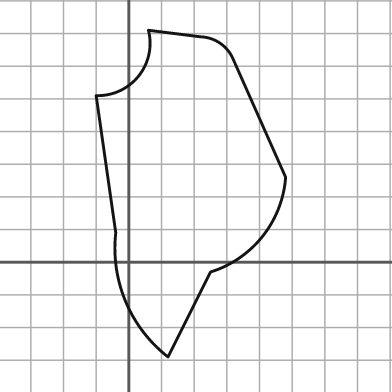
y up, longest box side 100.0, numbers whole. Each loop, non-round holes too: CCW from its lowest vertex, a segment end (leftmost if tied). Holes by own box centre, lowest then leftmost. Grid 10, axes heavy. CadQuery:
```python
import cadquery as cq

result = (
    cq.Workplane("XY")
    .moveTo(12.0, -29.0)
    .lineTo(25.0, -3.0)
    .threePointArc((41.0, 8.0), (48.0, 26.0))
    .lineTo(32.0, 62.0)
    .threePointArc((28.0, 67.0), (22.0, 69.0))
    .lineTo(6.0, 71.0)
    .threePointArc((3.0, 57.0), (-10.0, 51.0))
    .lineTo(-4.0, 9.0)
    .threePointArc((-1.0, -12.0), (12.0, -29.0))
    .close()
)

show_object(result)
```